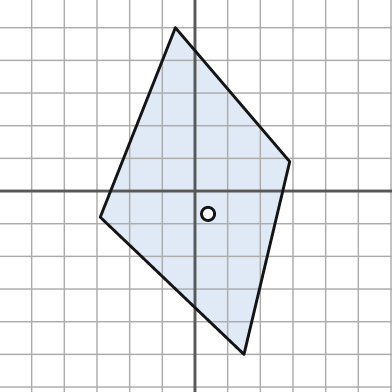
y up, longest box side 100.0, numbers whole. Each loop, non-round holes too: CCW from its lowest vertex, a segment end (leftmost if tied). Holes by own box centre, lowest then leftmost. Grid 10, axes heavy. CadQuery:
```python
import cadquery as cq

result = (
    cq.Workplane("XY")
    .moveTo(15.0, -50.0)
    .lineTo(29.0, 9.0)
    .lineTo(-6.0, 50.0)
    .lineTo(-29.0, -8.0)
    .close()
    .moveTo(4.0, -7.0)
    .circle(2.0)
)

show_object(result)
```